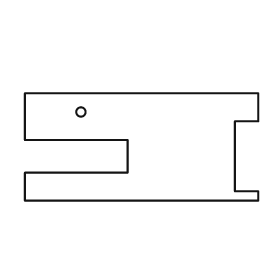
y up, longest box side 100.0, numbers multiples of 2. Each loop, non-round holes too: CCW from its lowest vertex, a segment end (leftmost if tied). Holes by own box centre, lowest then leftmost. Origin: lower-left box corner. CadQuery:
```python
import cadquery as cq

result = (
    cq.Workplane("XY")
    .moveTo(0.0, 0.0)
    .lineTo(100.0, 0.0)
    .lineTo(100.0, 4.0)
    .lineTo(90.0, 4.0)
    .lineTo(90.0, 34.0)
    .lineTo(100.0, 34.0)
    .lineTo(100.0, 46.0)
    .lineTo(0.0, 46.0)
    .lineTo(0.0, 26.0)
    .lineTo(44.0, 26.0)
    .lineTo(44.0, 12.0)
    .lineTo(0.0, 12.0)
    .close()
    .moveTo(24.0, 38.0)
    .circle(2.0)
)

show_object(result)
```